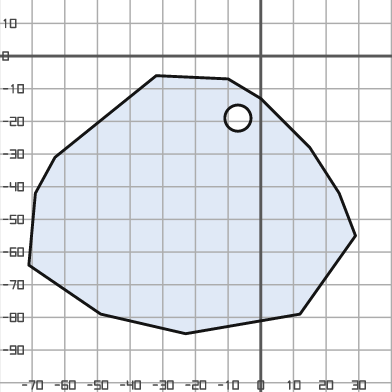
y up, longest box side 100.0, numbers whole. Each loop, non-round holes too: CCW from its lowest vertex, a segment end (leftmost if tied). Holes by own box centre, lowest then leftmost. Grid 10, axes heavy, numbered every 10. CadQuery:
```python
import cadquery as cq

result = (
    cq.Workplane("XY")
    .moveTo(-23.0, -85.0)
    .lineTo(12.0, -79.0)
    .lineTo(29.0, -55.0)
    .lineTo(24.0, -42.0)
    .lineTo(15.0, -28.0)
    .lineTo(0.0, -13.0)
    .lineTo(-10.0, -7.0)
    .lineTo(-32.0, -6.0)
    .lineTo(-63.0, -31.0)
    .lineTo(-69.0, -42.0)
    .lineTo(-71.0, -64.0)
    .lineTo(-49.0, -79.0)
    .close()
    .moveTo(-7.0, -19.0)
    .circle(4.0)
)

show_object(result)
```